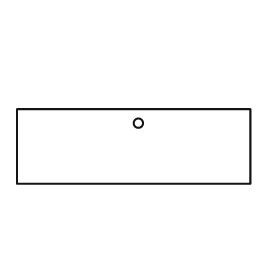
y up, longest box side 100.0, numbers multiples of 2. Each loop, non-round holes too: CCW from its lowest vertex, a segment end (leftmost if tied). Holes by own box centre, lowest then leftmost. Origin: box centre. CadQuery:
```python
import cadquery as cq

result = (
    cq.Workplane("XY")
    .moveTo(-50.0, -16.0)
    .lineTo(50.0, -16.0)
    .lineTo(50.0, 16.0)
    .lineTo(-50.0, 16.0)
    .close()
    .moveTo(2.0, 10.0)
    .circle(2.0)
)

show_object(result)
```